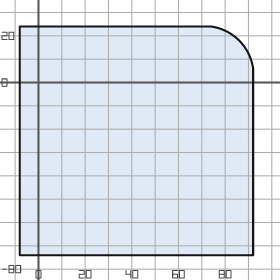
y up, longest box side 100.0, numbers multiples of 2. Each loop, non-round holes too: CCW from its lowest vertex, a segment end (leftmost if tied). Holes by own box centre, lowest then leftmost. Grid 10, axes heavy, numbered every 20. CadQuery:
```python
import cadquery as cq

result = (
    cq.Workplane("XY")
    .moveTo(-8.0, -74.0)
    .lineTo(92.0, -74.0)
    .lineTo(92.0, 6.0)
    .threePointArc((86.0, 18.0), (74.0, 24.0))
    .lineTo(-8.0, 24.0)
    .close()
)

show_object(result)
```